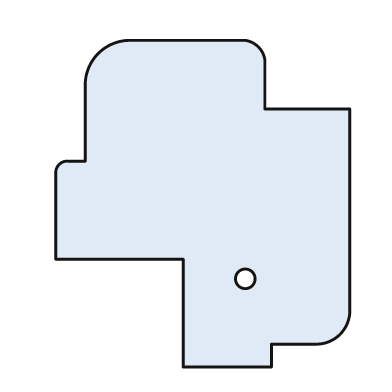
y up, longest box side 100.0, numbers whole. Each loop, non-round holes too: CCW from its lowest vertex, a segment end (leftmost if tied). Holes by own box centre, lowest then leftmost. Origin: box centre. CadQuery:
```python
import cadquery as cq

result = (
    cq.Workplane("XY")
    .moveTo(-6.0, -50.0)
    .lineTo(21.0, -50.0)
    .lineTo(21.0, -43.0)
    .lineTo(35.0, -43.0)
    .threePointArc((42.0, -40.0), (45.0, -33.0))
    .lineTo(45.0, 29.0)
    .lineTo(19.0, 29.0)
    .lineTo(19.0, 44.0)
    .threePointArc((17.0, 48.0), (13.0, 50.0))
    .lineTo(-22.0, 50.0)
    .threePointArc((-32.0, 46.0), (-36.0, 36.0))
    .lineTo(-36.0, 13.0)
    .lineTo(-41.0, 13.0)
    .threePointArc((-44.0, 12.0), (-45.0, 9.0))
    .lineTo(-45.0, -17.0)
    .lineTo(-6.0, -17.0)
    .close()
    .moveTo(13.0, -23.0)
    .circle(3.0)
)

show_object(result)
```